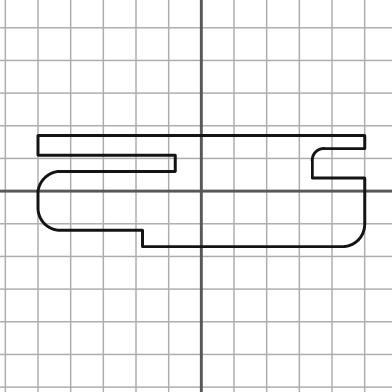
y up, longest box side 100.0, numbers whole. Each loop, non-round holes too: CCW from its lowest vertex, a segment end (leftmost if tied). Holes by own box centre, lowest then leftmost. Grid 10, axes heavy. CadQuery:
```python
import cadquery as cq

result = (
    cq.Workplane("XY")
    .moveTo(-18.0, -17.0)
    .lineTo(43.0, -17.0)
    .threePointArc((48.0, -15.0), (50.0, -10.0))
    .lineTo(50.0, 4.0)
    .lineTo(34.0, 4.0)
    .lineTo(34.0, 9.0)
    .threePointArc((35.0, 12.0), (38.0, 13.0))
    .lineTo(50.0, 13.0)
    .lineTo(50.0, 17.0)
    .lineTo(-50.0, 17.0)
    .lineTo(-50.0, 11.0)
    .lineTo(-8.0, 11.0)
    .lineTo(-8.0, 6.0)
    .lineTo(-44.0, 6.0)
    .threePointArc((-48.0, 4.0), (-50.0, 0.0))
    .lineTo(-50.0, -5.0)
    .threePointArc((-48.0, -10.0), (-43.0, -12.0))
    .lineTo(-18.0, -12.0)
    .close()
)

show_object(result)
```